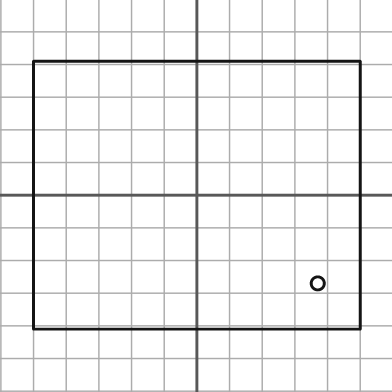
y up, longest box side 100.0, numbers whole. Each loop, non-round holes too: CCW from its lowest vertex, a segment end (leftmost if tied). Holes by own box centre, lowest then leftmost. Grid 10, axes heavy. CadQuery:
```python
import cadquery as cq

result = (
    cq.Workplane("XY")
    .moveTo(-50.0, -41.0)
    .lineTo(50.0, -41.0)
    .lineTo(50.0, 41.0)
    .lineTo(-50.0, 41.0)
    .close()
    .moveTo(37.0, -27.0)
    .circle(2.0)
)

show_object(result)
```